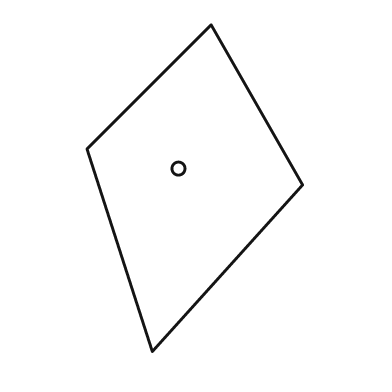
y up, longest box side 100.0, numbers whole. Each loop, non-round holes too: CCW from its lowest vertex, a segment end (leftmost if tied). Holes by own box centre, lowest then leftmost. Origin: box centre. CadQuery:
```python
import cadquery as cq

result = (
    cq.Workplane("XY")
    .moveTo(-13.0, -50.0)
    .lineTo(33.0, 1.0)
    .lineTo(5.0, 50.0)
    .lineTo(-33.0, 12.0)
    .close()
    .moveTo(-5.0, 6.0)
    .circle(2.0)
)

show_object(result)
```